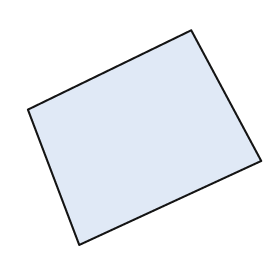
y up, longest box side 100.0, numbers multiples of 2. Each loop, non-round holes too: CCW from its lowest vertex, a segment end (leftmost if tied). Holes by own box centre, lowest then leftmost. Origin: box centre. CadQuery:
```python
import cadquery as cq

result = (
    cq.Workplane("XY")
    .moveTo(-28.0, -46.0)
    .lineTo(50.0, -10.0)
    .lineTo(20.0, 46.0)
    .lineTo(-50.0, 12.0)
    .close()
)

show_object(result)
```